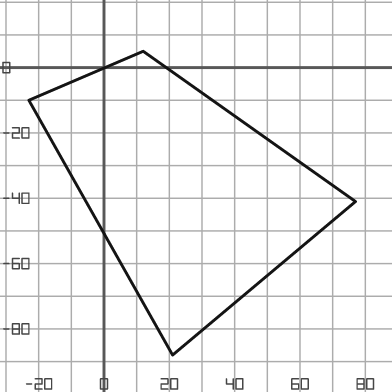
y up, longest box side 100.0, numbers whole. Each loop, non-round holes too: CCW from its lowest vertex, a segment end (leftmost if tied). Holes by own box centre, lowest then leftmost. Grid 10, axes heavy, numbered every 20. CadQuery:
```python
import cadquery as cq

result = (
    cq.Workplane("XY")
    .moveTo(21.0, -88.0)
    .lineTo(77.0, -41.0)
    .lineTo(12.0, 5.0)
    .lineTo(-23.0, -10.0)
    .close()
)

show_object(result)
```